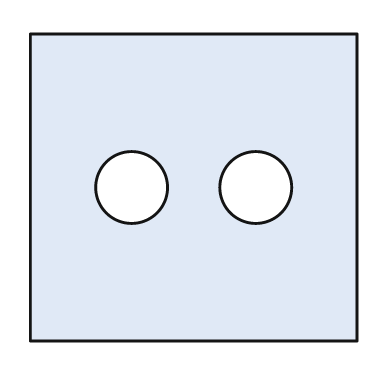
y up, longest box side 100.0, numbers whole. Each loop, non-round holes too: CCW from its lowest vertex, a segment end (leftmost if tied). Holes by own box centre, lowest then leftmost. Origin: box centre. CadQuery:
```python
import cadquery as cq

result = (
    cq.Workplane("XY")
    .moveTo(-50.0, -47.0)
    .lineTo(50.0, -47.0)
    .lineTo(50.0, 47.0)
    .lineTo(-50.0, 47.0)
    .close()
    .moveTo(-19.0, 0.0)
    .circle(11.0)
    .moveTo(19.0, 0.0)
    .circle(11.0)
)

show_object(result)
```